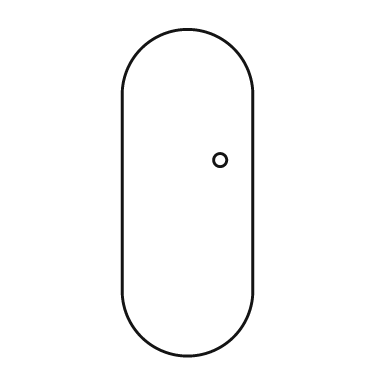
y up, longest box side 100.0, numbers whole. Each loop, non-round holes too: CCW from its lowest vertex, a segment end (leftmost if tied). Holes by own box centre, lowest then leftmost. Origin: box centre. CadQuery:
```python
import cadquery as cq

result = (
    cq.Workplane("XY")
    .moveTo(-20.0, -30.0)
    .threePointArc((0.0, -50.0), (20.0, -30.0))
    .lineTo(20.0, 30.0)
    .threePointArc((0.0, 50.0), (-20.0, 30.0))
    .close()
    .moveTo(10.0, 10.0)
    .circle(2.0)
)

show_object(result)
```